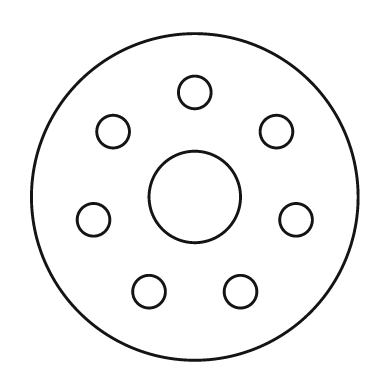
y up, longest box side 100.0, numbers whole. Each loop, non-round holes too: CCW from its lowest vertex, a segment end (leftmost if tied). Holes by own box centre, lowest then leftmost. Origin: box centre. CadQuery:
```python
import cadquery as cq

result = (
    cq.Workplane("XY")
    .moveTo(0.0, 0.0)
    .circle(50.0)
    .moveTo(-14.0, -29.0)
    .circle(5.0)
    .moveTo(14.0, -29.0)
    .circle(5.0)
    .moveTo(-31.0, -7.0)
    .circle(5.0)
    .moveTo(31.0, -7.0)
    .circle(5.0)
    .moveTo(0.0, 0.0)
    .circle(14.0)
    .moveTo(-25.0, 20.0)
    .circle(5.0)
    .moveTo(25.0, 20.0)
    .circle(5.0)
    .moveTo(0.0, 32.0)
    .circle(5.0)
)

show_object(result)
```